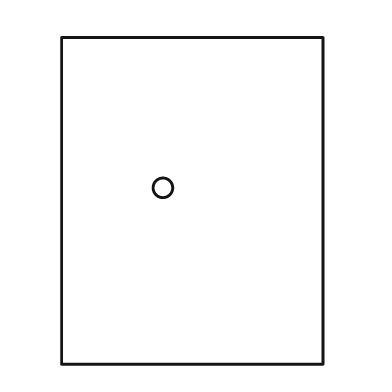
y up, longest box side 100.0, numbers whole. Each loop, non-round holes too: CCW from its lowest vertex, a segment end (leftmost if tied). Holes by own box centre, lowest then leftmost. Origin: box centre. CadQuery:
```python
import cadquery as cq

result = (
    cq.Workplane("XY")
    .moveTo(-40.0, -50.0)
    .lineTo(40.0, -50.0)
    .lineTo(40.0, 50.0)
    .lineTo(-40.0, 50.0)
    .close()
    .moveTo(-9.0, 4.0)
    .circle(3.0)
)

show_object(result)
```